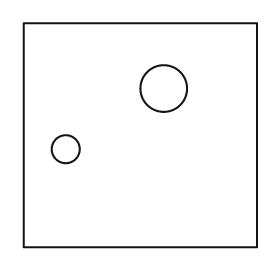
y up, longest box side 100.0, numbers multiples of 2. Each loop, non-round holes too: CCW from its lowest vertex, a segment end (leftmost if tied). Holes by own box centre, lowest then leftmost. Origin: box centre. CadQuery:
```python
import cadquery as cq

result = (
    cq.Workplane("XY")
    .moveTo(-50.0, -48.0)
    .lineTo(50.0, -48.0)
    .lineTo(50.0, 48.0)
    .lineTo(-50.0, 48.0)
    .close()
    .moveTo(-32.0, -6.0)
    .circle(6.0)
    .moveTo(10.0, 20.0)
    .circle(10.0)
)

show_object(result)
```